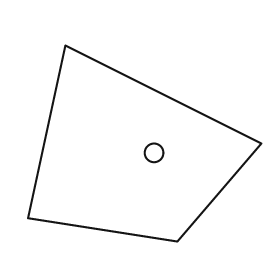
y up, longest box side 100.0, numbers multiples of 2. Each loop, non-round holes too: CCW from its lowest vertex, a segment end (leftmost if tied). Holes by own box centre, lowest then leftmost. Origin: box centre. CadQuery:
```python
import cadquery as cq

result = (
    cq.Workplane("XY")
    .moveTo(14.0, -42.0)
    .lineTo(50.0, 0.0)
    .lineTo(-34.0, 42.0)
    .lineTo(-50.0, -32.0)
    .close()
    .moveTo(4.0, -4.0)
    .circle(4.0)
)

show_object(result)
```